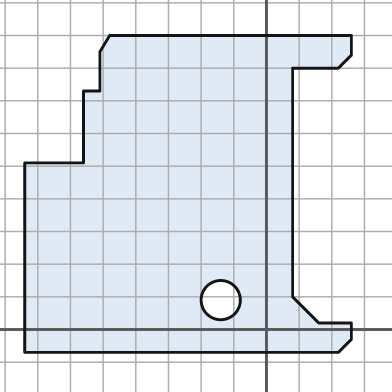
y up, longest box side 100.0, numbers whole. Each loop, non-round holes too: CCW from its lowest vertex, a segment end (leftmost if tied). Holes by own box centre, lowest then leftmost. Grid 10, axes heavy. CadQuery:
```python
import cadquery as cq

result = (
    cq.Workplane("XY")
    .moveTo(-74.0, -7.0)
    .lineTo(22.0, -7.0)
    .lineTo(26.0, -3.0)
    .lineTo(26.0, 2.0)
    .lineTo(16.0, 2.0)
    .lineTo(8.0, 10.0)
    .lineTo(8.0, 80.0)
    .lineTo(22.0, 80.0)
    .lineTo(26.0, 84.0)
    .lineTo(26.0, 90.0)
    .lineTo(-48.0, 90.0)
    .lineTo(-51.0, 85.0)
    .lineTo(-51.0, 73.0)
    .lineTo(-56.0, 73.0)
    .lineTo(-56.0, 51.0)
    .lineTo(-74.0, 51.0)
    .close()
    .moveTo(-14.0, 9.0)
    .circle(6.0)
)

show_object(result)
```